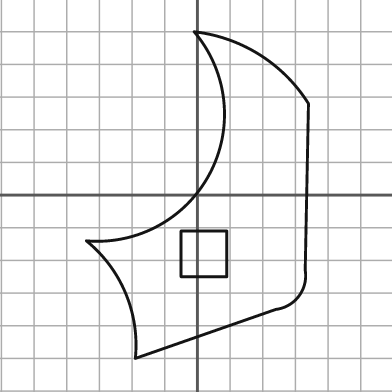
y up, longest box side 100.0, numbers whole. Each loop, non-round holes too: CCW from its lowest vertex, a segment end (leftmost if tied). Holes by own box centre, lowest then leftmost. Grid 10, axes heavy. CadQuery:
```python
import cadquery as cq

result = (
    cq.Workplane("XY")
    .moveTo(-19.0, -50.0)
    .lineTo(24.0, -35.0)
    .threePointArc((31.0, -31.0), (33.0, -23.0))
    .lineTo(34.0, 28.0)
    .threePointArc((19.0, 43.0), (-1.0, 50.0))
    .threePointArc((4.0, 7.0), (-34.0, -14.0))
    .threePointArc((-22.0, -30.0), (-19.0, -50.0))
    .close()
    .moveTo(-5.0, -25.0)
    .lineTo(9.0, -25.0)
    .lineTo(9.0, -11.0)
    .lineTo(-5.0, -11.0)
    .close()
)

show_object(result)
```